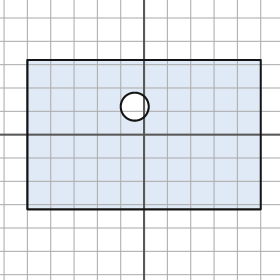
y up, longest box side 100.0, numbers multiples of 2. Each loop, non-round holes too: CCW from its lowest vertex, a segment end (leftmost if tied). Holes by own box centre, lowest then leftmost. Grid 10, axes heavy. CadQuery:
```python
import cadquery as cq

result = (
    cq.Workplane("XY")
    .moveTo(-50.0, -32.0)
    .lineTo(50.0, -32.0)
    .lineTo(50.0, 32.0)
    .lineTo(-50.0, 32.0)
    .close()
    .moveTo(-4.0, 12.0)
    .circle(6.0)
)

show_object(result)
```